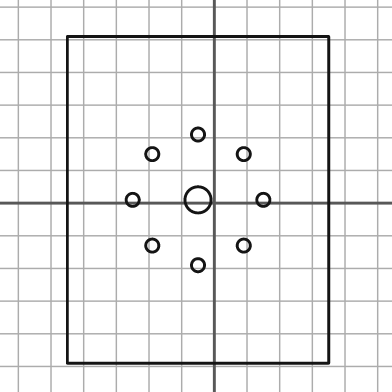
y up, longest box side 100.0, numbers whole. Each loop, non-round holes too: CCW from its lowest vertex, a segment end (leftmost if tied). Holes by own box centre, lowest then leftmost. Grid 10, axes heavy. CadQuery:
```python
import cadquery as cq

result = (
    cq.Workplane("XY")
    .moveTo(-45.0, -49.0)
    .lineTo(35.0, -49.0)
    .lineTo(35.0, 51.0)
    .lineTo(-45.0, 51.0)
    .close()
    .moveTo(-5.0, -19.0)
    .circle(2.0)
    .moveTo(-19.0, -13.0)
    .circle(2.0)
    .moveTo(9.0, -13.0)
    .circle(2.0)
    .moveTo(-25.0, 1.0)
    .circle(2.0)
    .moveTo(-5.0, 1.0)
    .circle(4.0)
    .moveTo(15.0, 1.0)
    .circle(2.0)
    .moveTo(-19.0, 15.0)
    .circle(2.0)
    .moveTo(9.0, 15.0)
    .circle(2.0)
    .moveTo(-5.0, 21.0)
    .circle(2.0)
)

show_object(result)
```